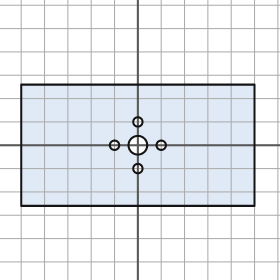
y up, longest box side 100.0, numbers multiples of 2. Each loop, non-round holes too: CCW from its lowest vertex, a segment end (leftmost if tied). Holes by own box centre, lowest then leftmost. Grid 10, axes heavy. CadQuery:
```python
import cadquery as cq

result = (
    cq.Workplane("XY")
    .moveTo(-50.0, -26.0)
    .lineTo(50.0, -26.0)
    .lineTo(50.0, 26.0)
    .lineTo(-50.0, 26.0)
    .close()
    .moveTo(0.0, -10.0)
    .circle(2.0)
    .moveTo(-10.0, 0.0)
    .circle(2.0)
    .moveTo(0.0, 0.0)
    .circle(4.0)
    .moveTo(10.0, 0.0)
    .circle(2.0)
    .moveTo(0.0, 10.0)
    .circle(2.0)
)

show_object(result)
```